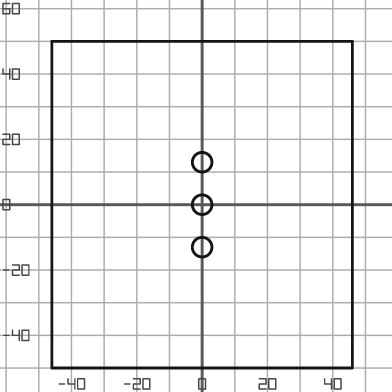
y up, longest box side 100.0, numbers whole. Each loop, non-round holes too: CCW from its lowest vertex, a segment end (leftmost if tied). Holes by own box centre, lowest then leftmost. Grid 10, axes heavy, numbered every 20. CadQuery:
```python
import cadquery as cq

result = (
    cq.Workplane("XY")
    .moveTo(-46.0, -50.0)
    .lineTo(46.0, -50.0)
    .lineTo(46.0, 50.0)
    .lineTo(-46.0, 50.0)
    .close()
    .moveTo(0.0, -13.0)
    .circle(3.0)
    .moveTo(0.0, 0.0)
    .circle(3.0)
    .moveTo(0.0, 13.0)
    .circle(3.0)
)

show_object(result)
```